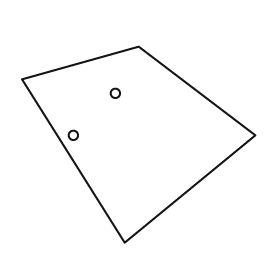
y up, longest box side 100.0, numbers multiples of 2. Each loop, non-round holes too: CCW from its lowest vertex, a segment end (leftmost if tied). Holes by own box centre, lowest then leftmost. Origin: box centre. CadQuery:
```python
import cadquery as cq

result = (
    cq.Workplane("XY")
    .moveTo(-6.0, -42.0)
    .lineTo(50.0, 4.0)
    .lineTo(0.0, 42.0)
    .lineTo(-50.0, 28.0)
    .close()
    .moveTo(-28.0, 4.0)
    .circle(2.0)
    .moveTo(-10.0, 22.0)
    .circle(2.0)
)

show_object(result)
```